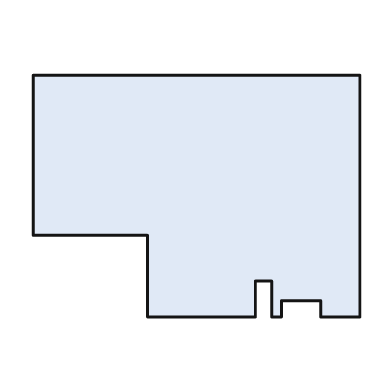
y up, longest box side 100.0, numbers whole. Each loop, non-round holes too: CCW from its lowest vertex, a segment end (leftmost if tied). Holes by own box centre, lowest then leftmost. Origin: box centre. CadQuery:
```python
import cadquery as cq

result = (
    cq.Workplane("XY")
    .moveTo(-15.0, -37.0)
    .lineTo(18.0, -37.0)
    .lineTo(18.0, -26.0)
    .lineTo(23.0, -26.0)
    .lineTo(23.0, -37.0)
    .lineTo(26.0, -37.0)
    .lineTo(26.0, -32.0)
    .lineTo(38.0, -32.0)
    .lineTo(38.0, -37.0)
    .lineTo(50.0, -37.0)
    .lineTo(50.0, 37.0)
    .lineTo(-50.0, 37.0)
    .lineTo(-50.0, -12.0)
    .lineTo(-15.0, -12.0)
    .close()
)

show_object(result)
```